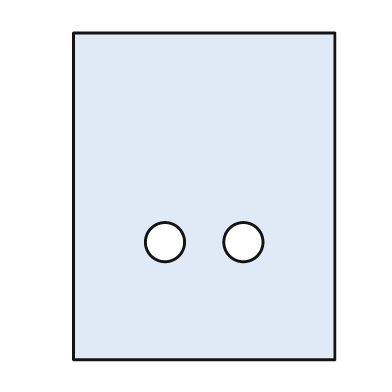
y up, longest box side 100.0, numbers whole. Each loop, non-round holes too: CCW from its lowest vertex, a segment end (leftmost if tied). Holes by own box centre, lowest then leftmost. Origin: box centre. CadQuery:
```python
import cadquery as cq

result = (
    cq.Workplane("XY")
    .moveTo(-40.0, -50.0)
    .lineTo(40.0, -50.0)
    .lineTo(40.0, 50.0)
    .lineTo(-40.0, 50.0)
    .close()
    .moveTo(-12.0, -14.0)
    .circle(6.0)
    .moveTo(12.0, -14.0)
    .circle(6.0)
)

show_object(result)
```